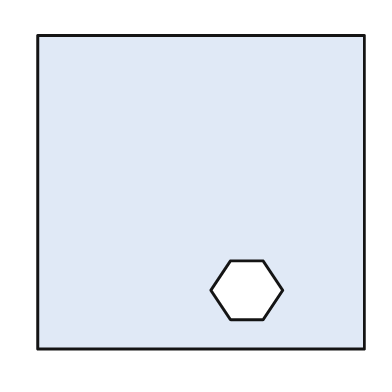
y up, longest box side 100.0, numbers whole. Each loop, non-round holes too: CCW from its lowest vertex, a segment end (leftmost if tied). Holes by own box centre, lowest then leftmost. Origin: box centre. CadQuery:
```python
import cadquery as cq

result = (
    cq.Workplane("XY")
    .moveTo(-50.0, -48.0)
    .lineTo(50.0, -48.0)
    .lineTo(50.0, 48.0)
    .lineTo(-50.0, 48.0)
    .close()
    .moveTo(9.0, -39.0)
    .lineTo(19.0, -39.0)
    .lineTo(25.0, -30.0)
    .lineTo(19.0, -21.0)
    .lineTo(9.0, -21.0)
    .lineTo(3.0, -30.0)
    .close()
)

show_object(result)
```